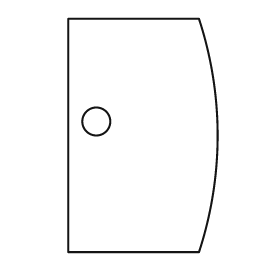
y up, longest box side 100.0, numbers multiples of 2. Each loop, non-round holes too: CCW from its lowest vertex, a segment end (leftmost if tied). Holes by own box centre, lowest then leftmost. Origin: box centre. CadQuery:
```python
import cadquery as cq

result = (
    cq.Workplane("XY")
    .moveTo(-32.0, -50.0)
    .lineTo(24.0, -50.0)
    .threePointArc((32.0, 0.0), (24.0, 50.0))
    .lineTo(-32.0, 50.0)
    .close()
    .moveTo(-20.0, 6.0)
    .circle(6.0)
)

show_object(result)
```